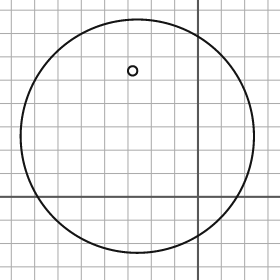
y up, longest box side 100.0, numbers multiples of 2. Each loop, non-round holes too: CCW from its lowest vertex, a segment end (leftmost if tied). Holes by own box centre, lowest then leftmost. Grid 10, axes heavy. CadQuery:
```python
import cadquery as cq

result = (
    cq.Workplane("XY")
    .moveTo(-26.0, 26.0)
    .circle(50.0)
    .moveTo(-28.0, 54.0)
    .circle(2.0)
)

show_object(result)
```